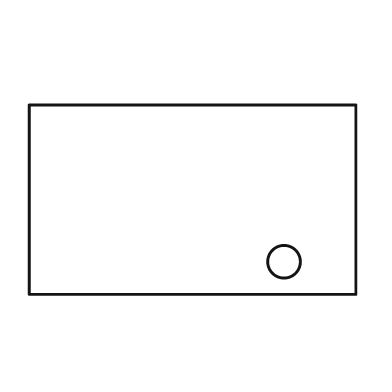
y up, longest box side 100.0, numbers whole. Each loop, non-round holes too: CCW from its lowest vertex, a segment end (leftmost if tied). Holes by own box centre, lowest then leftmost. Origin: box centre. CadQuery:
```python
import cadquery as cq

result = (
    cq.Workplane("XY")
    .moveTo(-50.0, -29.0)
    .lineTo(50.0, -29.0)
    .lineTo(50.0, 29.0)
    .lineTo(-50.0, 29.0)
    .close()
    .moveTo(28.0, -19.0)
    .circle(5.0)
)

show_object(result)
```